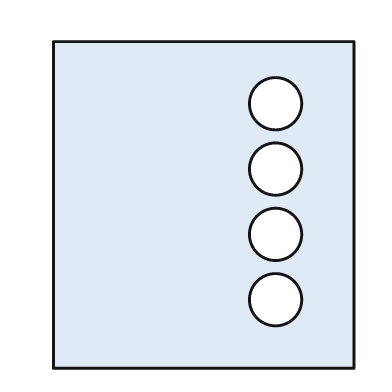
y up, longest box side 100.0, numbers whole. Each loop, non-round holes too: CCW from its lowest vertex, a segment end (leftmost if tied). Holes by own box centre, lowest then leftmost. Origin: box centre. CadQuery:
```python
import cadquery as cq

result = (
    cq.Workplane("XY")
    .moveTo(-46.0, -50.0)
    .lineTo(46.0, -50.0)
    .lineTo(46.0, 50.0)
    .lineTo(-46.0, 50.0)
    .close()
    .moveTo(22.0, -29.0)
    .circle(8.0)
    .moveTo(22.0, -9.0)
    .circle(8.0)
    .moveTo(22.0, 11.0)
    .circle(8.0)
    .moveTo(22.0, 31.0)
    .circle(8.0)
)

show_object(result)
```